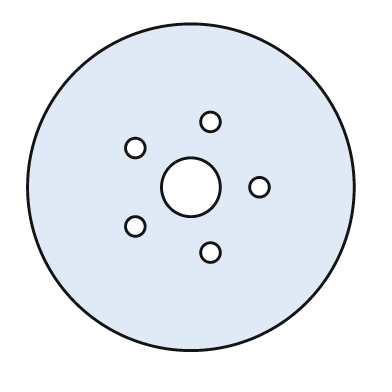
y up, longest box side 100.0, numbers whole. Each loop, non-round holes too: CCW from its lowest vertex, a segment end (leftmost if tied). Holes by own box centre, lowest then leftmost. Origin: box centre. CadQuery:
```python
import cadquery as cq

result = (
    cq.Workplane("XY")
    .moveTo(0.0, 0.0)
    .circle(50.0)
    .moveTo(6.0, -20.0)
    .circle(3.0)
    .moveTo(-17.0, -12.0)
    .circle(3.0)
    .moveTo(0.0, 0.0)
    .circle(9.0)
    .moveTo(21.0, 0.0)
    .circle(3.0)
    .moveTo(-17.0, 12.0)
    .circle(3.0)
    .moveTo(6.0, 20.0)
    .circle(3.0)
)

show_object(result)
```